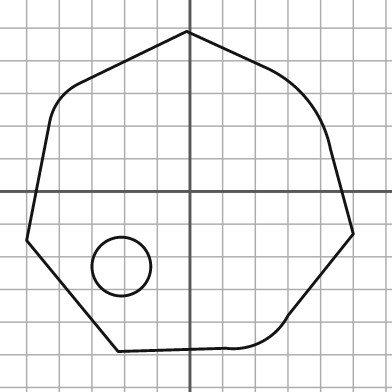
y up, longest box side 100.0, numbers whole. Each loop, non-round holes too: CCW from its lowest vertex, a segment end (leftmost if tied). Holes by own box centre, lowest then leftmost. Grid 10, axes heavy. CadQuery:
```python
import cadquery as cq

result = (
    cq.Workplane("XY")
    .moveTo(-22.0, -49.0)
    .lineTo(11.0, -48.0)
    .threePointArc((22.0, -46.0), (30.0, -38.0))
    .lineTo(50.0, -13.0)
    .lineTo(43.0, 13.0)
    .threePointArc((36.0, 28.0), (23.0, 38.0))
    .lineTo(-1.0, 49.0)
    .lineTo(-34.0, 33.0)
    .threePointArc((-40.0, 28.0), (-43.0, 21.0))
    .lineTo(-50.0, -15.0)
    .close()
    .moveTo(-21.0, -23.0)
    .circle(9.0)
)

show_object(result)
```